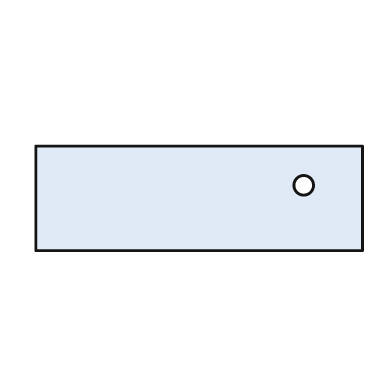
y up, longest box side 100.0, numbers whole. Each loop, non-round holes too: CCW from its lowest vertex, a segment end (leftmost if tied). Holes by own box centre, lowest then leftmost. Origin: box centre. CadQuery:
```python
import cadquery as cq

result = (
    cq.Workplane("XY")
    .moveTo(-50.0, -16.0)
    .lineTo(50.0, -16.0)
    .lineTo(50.0, 16.0)
    .lineTo(-50.0, 16.0)
    .close()
    .moveTo(32.0, 4.0)
    .circle(3.0)
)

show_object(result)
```